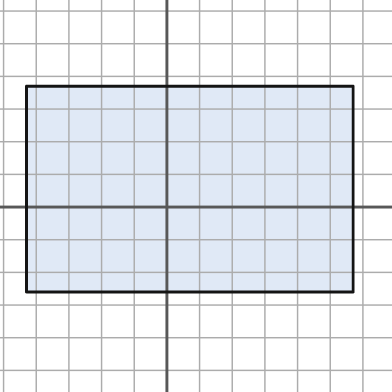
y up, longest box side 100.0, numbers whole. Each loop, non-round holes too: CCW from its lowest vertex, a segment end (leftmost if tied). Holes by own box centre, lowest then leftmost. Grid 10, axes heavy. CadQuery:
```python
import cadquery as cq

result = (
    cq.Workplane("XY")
    .moveTo(-43.0, -26.0)
    .lineTo(57.0, -26.0)
    .lineTo(57.0, 37.0)
    .lineTo(-43.0, 37.0)
    .close()
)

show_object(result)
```